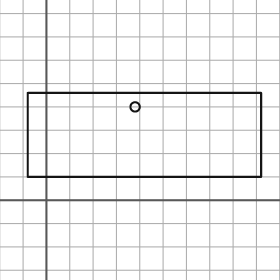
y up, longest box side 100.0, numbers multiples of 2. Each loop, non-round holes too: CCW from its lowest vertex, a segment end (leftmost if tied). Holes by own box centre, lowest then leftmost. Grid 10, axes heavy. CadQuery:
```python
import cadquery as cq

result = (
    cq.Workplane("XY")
    .moveTo(-8.0, 10.0)
    .lineTo(92.0, 10.0)
    .lineTo(92.0, 46.0)
    .lineTo(-8.0, 46.0)
    .close()
    .moveTo(38.0, 40.0)
    .circle(2.0)
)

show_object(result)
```